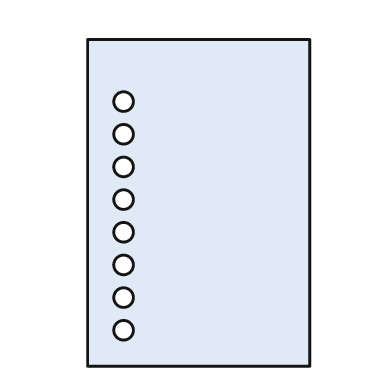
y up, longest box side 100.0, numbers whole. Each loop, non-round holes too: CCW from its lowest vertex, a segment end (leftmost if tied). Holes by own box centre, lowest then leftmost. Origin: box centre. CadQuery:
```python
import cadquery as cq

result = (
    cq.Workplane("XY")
    .moveTo(-34.0, -50.0)
    .lineTo(34.0, -50.0)
    .lineTo(34.0, 50.0)
    .lineTo(-34.0, 50.0)
    .close()
    .moveTo(-23.0, -39.0)
    .circle(3.0)
    .moveTo(-23.0, -29.0)
    .circle(3.0)
    .moveTo(-23.0, -19.0)
    .circle(3.0)
    .moveTo(-23.0, -9.0)
    .circle(3.0)
    .moveTo(-23.0, 1.0)
    .circle(3.0)
    .moveTo(-23.0, 11.0)
    .circle(3.0)
    .moveTo(-23.0, 21.0)
    .circle(3.0)
    .moveTo(-23.0, 31.0)
    .circle(3.0)
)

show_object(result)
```